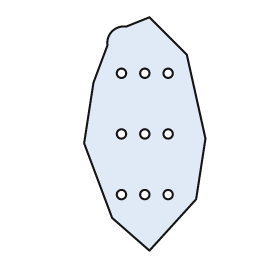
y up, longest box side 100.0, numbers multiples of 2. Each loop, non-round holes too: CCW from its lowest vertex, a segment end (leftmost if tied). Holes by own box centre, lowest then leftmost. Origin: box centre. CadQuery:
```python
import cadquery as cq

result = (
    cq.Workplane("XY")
    .moveTo(2.0, -50.0)
    .lineTo(22.0, -28.0)
    .lineTo(26.0, -2.0)
    .lineTo(18.0, 34.0)
    .lineTo(2.0, 50.0)
    .lineTo(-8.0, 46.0)
    .threePointArc((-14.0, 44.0), (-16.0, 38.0))
    .lineTo(-22.0, 22.0)
    .lineTo(-26.0, -4.0)
    .lineTo(-14.0, -36.0)
    .close()
    .moveTo(-10.0, -26.0)
    .circle(2.0)
    .moveTo(0.0, -26.0)
    .circle(2.0)
    .moveTo(10.0, -26.0)
    .circle(2.0)
    .moveTo(-10.0, 0.0)
    .circle(2.0)
    .moveTo(0.0, 0.0)
    .circle(2.0)
    .moveTo(10.0, 0.0)
    .circle(2.0)
    .moveTo(-10.0, 26.0)
    .circle(2.0)
    .moveTo(0.0, 26.0)
    .circle(2.0)
    .moveTo(10.0, 26.0)
    .circle(2.0)
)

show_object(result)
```